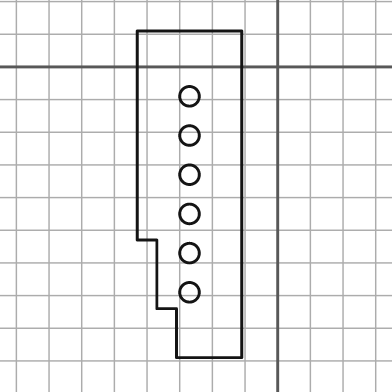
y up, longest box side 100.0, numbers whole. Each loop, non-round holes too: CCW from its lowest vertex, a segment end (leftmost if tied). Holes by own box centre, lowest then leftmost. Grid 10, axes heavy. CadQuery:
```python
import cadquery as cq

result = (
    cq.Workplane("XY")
    .moveTo(-31.0, -89.0)
    .lineTo(-11.0, -89.0)
    .lineTo(-11.0, 11.0)
    .lineTo(-43.0, 11.0)
    .lineTo(-43.0, -53.0)
    .lineTo(-37.0, -53.0)
    .lineTo(-37.0, -74.0)
    .lineTo(-31.0, -74.0)
    .close()
    .moveTo(-27.0, -69.0)
    .circle(3.0)
    .moveTo(-27.0, -57.0)
    .circle(3.0)
    .moveTo(-27.0, -45.0)
    .circle(3.0)
    .moveTo(-27.0, -33.0)
    .circle(3.0)
    .moveTo(-27.0, -21.0)
    .circle(3.0)
    .moveTo(-27.0, -9.0)
    .circle(3.0)
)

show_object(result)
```